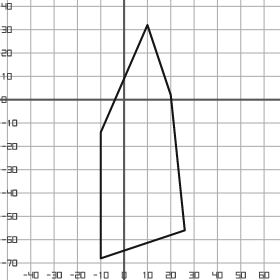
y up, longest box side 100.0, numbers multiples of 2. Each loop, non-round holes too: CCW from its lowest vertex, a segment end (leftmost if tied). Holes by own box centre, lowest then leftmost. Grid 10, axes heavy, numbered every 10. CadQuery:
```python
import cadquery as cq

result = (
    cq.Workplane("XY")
    .moveTo(-10.0, -68.0)
    .lineTo(26.0, -56.0)
    .lineTo(20.0, 2.0)
    .lineTo(10.0, 32.0)
    .lineTo(-10.0, -14.0)
    .close()
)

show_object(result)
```